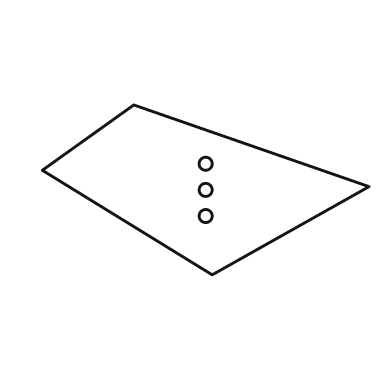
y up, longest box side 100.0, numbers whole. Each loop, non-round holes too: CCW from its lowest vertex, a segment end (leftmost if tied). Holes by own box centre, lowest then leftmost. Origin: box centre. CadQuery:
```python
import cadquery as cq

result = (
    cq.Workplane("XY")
    .moveTo(2.0, -26.0)
    .lineTo(50.0, 1.0)
    .lineTo(-22.0, 26.0)
    .lineTo(-50.0, 6.0)
    .close()
    .moveTo(0.0, -8.0)
    .circle(2.0)
    .moveTo(0.0, 0.0)
    .circle(2.0)
    .moveTo(0.0, 8.0)
    .circle(2.0)
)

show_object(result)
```